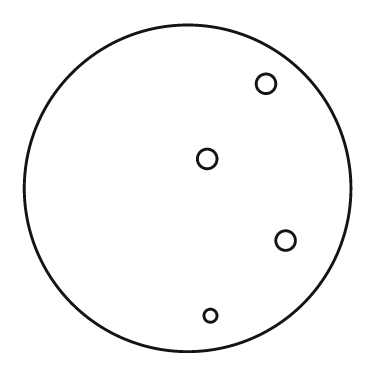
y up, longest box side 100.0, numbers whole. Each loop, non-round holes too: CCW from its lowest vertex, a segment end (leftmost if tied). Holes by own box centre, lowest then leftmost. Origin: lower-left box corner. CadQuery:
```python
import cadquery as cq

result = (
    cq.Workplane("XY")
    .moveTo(50.0, 50.0)
    .circle(50.0)
    .moveTo(57.0, 11.0)
    .circle(2.0)
    .moveTo(80.0, 34.0)
    .circle(3.0)
    .moveTo(56.0, 59.0)
    .circle(3.0)
    .moveTo(74.0, 82.0)
    .circle(3.0)
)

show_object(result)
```